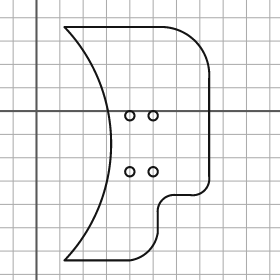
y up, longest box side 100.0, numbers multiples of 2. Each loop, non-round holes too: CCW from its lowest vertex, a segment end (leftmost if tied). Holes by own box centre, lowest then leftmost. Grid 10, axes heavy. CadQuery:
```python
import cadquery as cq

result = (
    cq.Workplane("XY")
    .moveTo(12.0, -64.0)
    .lineTo(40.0, -64.0)
    .threePointArc((48.0, -60.0), (52.0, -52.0))
    .lineTo(52.0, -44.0)
    .threePointArc((54.0, -38.0), (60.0, -36.0))
    .lineTo(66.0, -36.0)
    .threePointArc((72.0, -34.0), (74.0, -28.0))
    .lineTo(74.0, 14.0)
    .threePointArc((68.0, 30.0), (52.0, 36.0))
    .lineTo(12.0, 36.0)
    .threePointArc((32.0, -14.0), (12.0, -64.0))
    .close()
    .moveTo(40.0, -26.0)
    .circle(2.0)
    .moveTo(50.0, -26.0)
    .circle(2.0)
    .moveTo(40.0, -2.0)
    .circle(2.0)
    .moveTo(50.0, -2.0)
    .circle(2.0)
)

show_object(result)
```